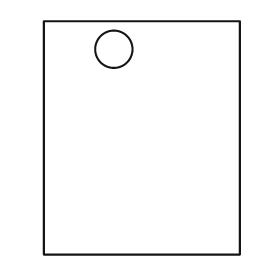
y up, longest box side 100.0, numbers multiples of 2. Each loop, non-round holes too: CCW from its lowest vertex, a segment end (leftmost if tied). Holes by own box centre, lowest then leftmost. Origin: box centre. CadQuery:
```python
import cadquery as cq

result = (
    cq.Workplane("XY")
    .moveTo(-42.0, -50.0)
    .lineTo(42.0, -50.0)
    .lineTo(42.0, 50.0)
    .lineTo(-42.0, 50.0)
    .close()
    .moveTo(-12.0, 38.0)
    .circle(8.0)
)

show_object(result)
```